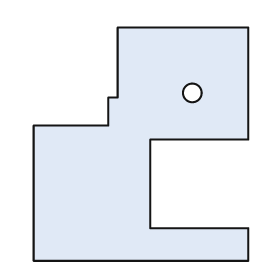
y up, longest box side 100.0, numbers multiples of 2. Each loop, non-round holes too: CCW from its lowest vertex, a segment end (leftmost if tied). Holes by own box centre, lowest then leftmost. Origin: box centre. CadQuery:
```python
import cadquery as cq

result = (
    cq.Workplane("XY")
    .moveTo(-46.0, -50.0)
    .lineTo(46.0, -50.0)
    .lineTo(46.0, -36.0)
    .lineTo(4.0, -36.0)
    .lineTo(4.0, 2.0)
    .lineTo(46.0, 2.0)
    .lineTo(46.0, 50.0)
    .lineTo(-10.0, 50.0)
    .lineTo(-10.0, 20.0)
    .lineTo(-14.0, 20.0)
    .lineTo(-14.0, 8.0)
    .lineTo(-46.0, 8.0)
    .close()
    .moveTo(22.0, 22.0)
    .circle(4.0)
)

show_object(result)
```